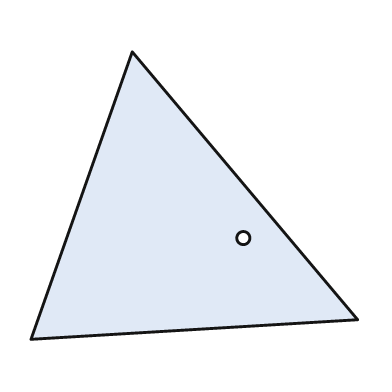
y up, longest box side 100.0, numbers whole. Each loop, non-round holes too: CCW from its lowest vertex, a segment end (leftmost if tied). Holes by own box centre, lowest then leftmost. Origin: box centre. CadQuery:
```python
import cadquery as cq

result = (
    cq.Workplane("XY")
    .moveTo(-50.0, -44.0)
    .lineTo(50.0, -38.0)
    .lineTo(-19.0, 44.0)
    .close()
    .moveTo(15.0, -13.0)
    .circle(2.0)
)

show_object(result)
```